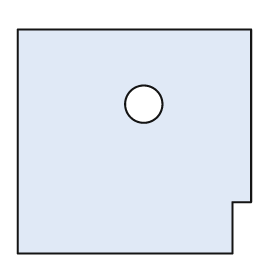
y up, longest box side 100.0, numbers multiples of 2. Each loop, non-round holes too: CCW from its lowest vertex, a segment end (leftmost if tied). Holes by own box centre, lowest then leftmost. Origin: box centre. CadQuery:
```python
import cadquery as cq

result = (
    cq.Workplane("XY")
    .moveTo(-50.0, -48.0)
    .lineTo(42.0, -48.0)
    .lineTo(42.0, -26.0)
    .lineTo(50.0, -26.0)
    .lineTo(50.0, 48.0)
    .lineTo(-50.0, 48.0)
    .close()
    .moveTo(4.0, 16.0)
    .circle(8.0)
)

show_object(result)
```